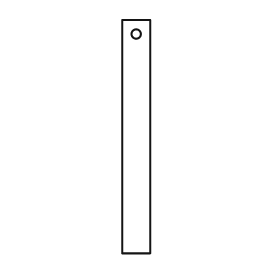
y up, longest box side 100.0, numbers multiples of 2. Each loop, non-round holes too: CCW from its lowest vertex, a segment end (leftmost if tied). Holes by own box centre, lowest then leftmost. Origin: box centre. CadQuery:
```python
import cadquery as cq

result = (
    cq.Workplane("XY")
    .moveTo(-6.0, -50.0)
    .lineTo(6.0, -50.0)
    .lineTo(6.0, 50.0)
    .lineTo(-6.0, 50.0)
    .close()
    .moveTo(0.0, 44.0)
    .circle(2.0)
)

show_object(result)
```